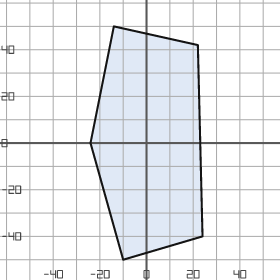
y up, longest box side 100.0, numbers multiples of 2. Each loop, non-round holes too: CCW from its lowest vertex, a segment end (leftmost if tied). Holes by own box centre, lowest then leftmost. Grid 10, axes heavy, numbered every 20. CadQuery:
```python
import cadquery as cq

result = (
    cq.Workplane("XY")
    .moveTo(-10.0, -50.0)
    .lineTo(24.0, -40.0)
    .lineTo(22.0, 42.0)
    .lineTo(-14.0, 50.0)
    .lineTo(-24.0, 0.0)
    .close()
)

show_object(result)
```